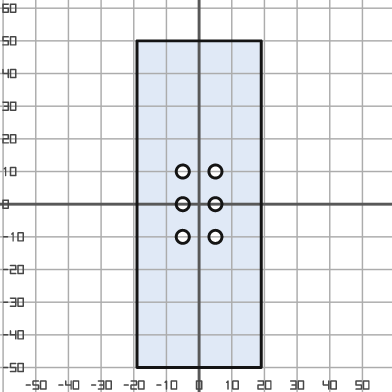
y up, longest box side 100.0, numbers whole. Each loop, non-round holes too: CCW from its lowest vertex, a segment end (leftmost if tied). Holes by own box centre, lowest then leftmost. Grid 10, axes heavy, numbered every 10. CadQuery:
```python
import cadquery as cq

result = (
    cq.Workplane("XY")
    .moveTo(-19.0, -50.0)
    .lineTo(19.0, -50.0)
    .lineTo(19.0, 50.0)
    .lineTo(-19.0, 50.0)
    .close()
    .moveTo(-5.0, -10.0)
    .circle(2.0)
    .moveTo(5.0, -10.0)
    .circle(2.0)
    .moveTo(-5.0, 0.0)
    .circle(2.0)
    .moveTo(5.0, 0.0)
    .circle(2.0)
    .moveTo(-5.0, 10.0)
    .circle(2.0)
    .moveTo(5.0, 10.0)
    .circle(2.0)
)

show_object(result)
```